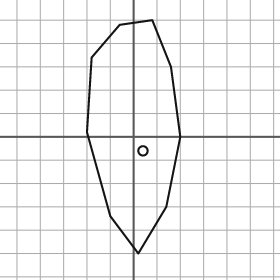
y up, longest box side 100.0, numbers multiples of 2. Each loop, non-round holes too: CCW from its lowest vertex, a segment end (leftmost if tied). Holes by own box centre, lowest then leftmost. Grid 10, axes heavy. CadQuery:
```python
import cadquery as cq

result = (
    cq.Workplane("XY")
    .moveTo(2.0, -50.0)
    .lineTo(14.0, -30.0)
    .lineTo(20.0, 0.0)
    .lineTo(16.0, 30.0)
    .lineTo(8.0, 50.0)
    .lineTo(-6.0, 48.0)
    .lineTo(-18.0, 34.0)
    .lineTo(-20.0, 2.0)
    .lineTo(-10.0, -34.0)
    .close()
    .moveTo(4.0, -6.0)
    .circle(2.0)
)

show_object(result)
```